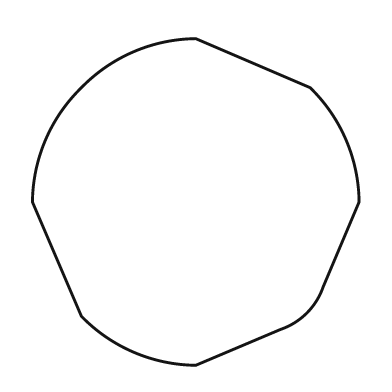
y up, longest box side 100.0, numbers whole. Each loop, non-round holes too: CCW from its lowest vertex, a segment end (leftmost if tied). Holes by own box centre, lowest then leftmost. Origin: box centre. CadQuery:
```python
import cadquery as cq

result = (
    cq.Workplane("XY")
    .moveTo(0.0, -50.0)
    .lineTo(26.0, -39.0)
    .threePointArc((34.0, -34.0), (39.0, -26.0))
    .lineTo(50.0, 0.0)
    .threePointArc((46.0, 19.0), (35.0, 35.0))
    .lineTo(0.0, 50.0)
    .threePointArc((-19.0, 46.0), (-35.0, 35.0))
    .threePointArc((-46.0, 19.0), (-50.0, 0.0))
    .lineTo(-35.0, -35.0)
    .threePointArc((-19.0, -46.0), (0.0, -50.0))
    .close()
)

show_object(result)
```